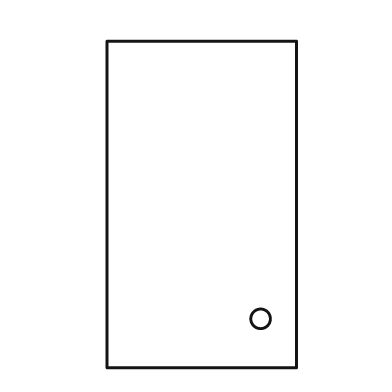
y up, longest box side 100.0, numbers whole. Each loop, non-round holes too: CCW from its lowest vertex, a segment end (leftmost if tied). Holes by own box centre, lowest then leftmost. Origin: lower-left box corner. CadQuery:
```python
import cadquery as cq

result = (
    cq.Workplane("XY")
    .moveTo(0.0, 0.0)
    .lineTo(58.0, 0.0)
    .lineTo(58.0, 100.0)
    .lineTo(0.0, 100.0)
    .close()
    .moveTo(47.0, 15.0)
    .circle(3.0)
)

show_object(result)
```